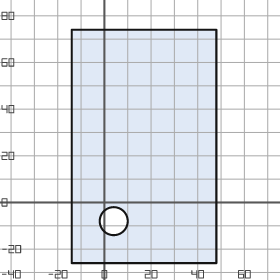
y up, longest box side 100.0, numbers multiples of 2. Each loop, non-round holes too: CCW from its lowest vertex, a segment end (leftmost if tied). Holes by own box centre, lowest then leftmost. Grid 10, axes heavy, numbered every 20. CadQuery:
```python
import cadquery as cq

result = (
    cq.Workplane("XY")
    .moveTo(-14.0, -26.0)
    .lineTo(48.0, -26.0)
    .lineTo(48.0, 74.0)
    .lineTo(-14.0, 74.0)
    .close()
    .moveTo(4.0, -8.0)
    .circle(6.0)
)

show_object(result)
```